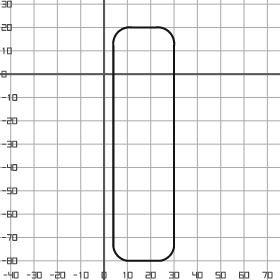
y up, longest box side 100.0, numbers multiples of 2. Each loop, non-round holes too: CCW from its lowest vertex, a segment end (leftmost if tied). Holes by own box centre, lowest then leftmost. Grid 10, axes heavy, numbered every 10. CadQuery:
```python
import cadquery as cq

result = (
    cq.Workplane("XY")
    .moveTo(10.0, -80.0)
    .lineTo(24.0, -80.0)
    .threePointArc((28.0, -78.0), (30.0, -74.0))
    .lineTo(30.0, 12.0)
    .threePointArc((28.0, 18.0), (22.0, 20.0))
    .lineTo(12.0, 20.0)
    .threePointArc((6.0, 18.0), (4.0, 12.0))
    .lineTo(4.0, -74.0)
    .threePointArc((6.0, -78.0), (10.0, -80.0))
    .close()
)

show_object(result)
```